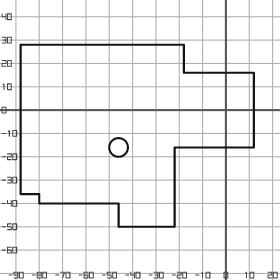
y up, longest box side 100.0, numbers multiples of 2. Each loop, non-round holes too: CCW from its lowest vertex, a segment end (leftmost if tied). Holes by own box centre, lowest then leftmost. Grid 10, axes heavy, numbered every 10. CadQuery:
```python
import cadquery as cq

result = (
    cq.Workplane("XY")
    .moveTo(-46.0, -50.0)
    .lineTo(-22.0, -50.0)
    .lineTo(-22.0, -16.0)
    .lineTo(12.0, -16.0)
    .lineTo(12.0, 16.0)
    .lineTo(-18.0, 16.0)
    .lineTo(-18.0, 28.0)
    .lineTo(-88.0, 28.0)
    .lineTo(-88.0, -36.0)
    .lineTo(-80.0, -36.0)
    .lineTo(-80.0, -40.0)
    .lineTo(-46.0, -40.0)
    .close()
    .moveTo(-46.0, -16.0)
    .circle(4.0)
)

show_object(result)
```